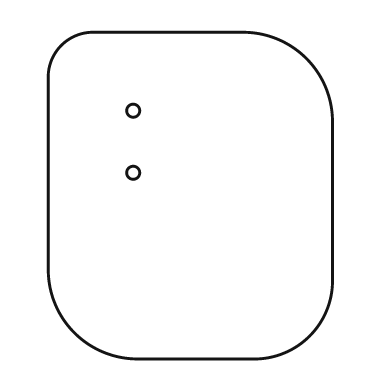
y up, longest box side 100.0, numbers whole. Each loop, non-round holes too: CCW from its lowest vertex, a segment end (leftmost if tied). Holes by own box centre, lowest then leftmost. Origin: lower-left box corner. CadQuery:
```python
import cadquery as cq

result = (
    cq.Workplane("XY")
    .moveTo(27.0, 0.0)
    .lineTo(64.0, 0.0)
    .threePointArc((80.0, 7.0), (87.0, 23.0))
    .lineTo(87.0, 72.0)
    .threePointArc((79.0, 92.0), (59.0, 100.0))
    .lineTo(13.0, 100.0)
    .threePointArc((4.0, 96.0), (0.0, 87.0))
    .lineTo(0.0, 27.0)
    .threePointArc((8.0, 8.0), (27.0, 0.0))
    .close()
    .moveTo(26.0, 57.0)
    .circle(2.0)
    .moveTo(26.0, 76.0)
    .circle(2.0)
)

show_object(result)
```